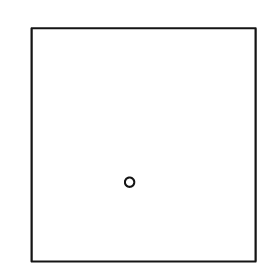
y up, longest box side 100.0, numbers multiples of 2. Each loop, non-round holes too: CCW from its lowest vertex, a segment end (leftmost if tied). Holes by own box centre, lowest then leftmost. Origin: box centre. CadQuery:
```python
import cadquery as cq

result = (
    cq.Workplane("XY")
    .moveTo(-48.0, -50.0)
    .lineTo(48.0, -50.0)
    .lineTo(48.0, 50.0)
    .lineTo(-48.0, 50.0)
    .close()
    .moveTo(-6.0, -16.0)
    .circle(2.0)
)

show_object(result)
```